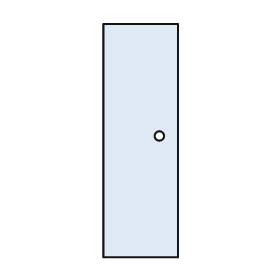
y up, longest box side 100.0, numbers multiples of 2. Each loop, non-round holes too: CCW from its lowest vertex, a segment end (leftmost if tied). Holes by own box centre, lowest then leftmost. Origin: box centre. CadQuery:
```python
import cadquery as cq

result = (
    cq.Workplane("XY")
    .moveTo(-16.0, -50.0)
    .lineTo(16.0, -50.0)
    .lineTo(16.0, 50.0)
    .lineTo(-16.0, 50.0)
    .close()
    .moveTo(8.0, 2.0)
    .circle(2.0)
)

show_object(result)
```